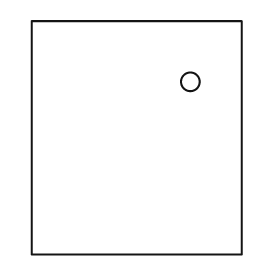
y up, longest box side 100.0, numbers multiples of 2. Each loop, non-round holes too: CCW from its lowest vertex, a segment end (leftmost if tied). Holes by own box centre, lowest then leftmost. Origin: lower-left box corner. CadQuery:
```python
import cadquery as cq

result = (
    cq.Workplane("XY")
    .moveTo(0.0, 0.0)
    .lineTo(90.0, 0.0)
    .lineTo(90.0, 100.0)
    .lineTo(0.0, 100.0)
    .close()
    .moveTo(68.0, 74.0)
    .circle(4.0)
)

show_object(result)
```